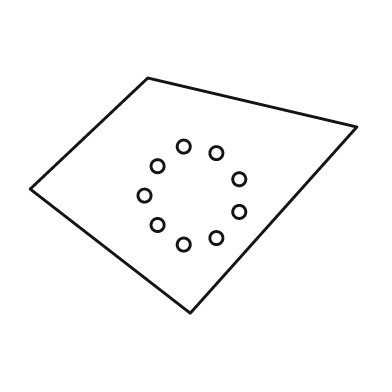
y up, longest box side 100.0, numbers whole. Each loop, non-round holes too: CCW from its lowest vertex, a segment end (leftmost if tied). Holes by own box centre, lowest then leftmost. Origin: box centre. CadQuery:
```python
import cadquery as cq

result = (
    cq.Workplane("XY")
    .moveTo(-1.0, -36.0)
    .lineTo(50.0, 21.0)
    .lineTo(-14.0, 36.0)
    .lineTo(-50.0, 2.0)
    .close()
    .moveTo(-3.0, -15.0)
    .circle(2.0)
    .moveTo(7.0, -13.0)
    .circle(2.0)
    .moveTo(-11.0, -9.0)
    .circle(2.0)
    .moveTo(14.0, -5.0)
    .circle(2.0)
    .moveTo(-15.0, 0.0)
    .circle(2.0)
    .moveTo(14.0, 5.0)
    .circle(2.0)
    .moveTo(-11.0, 9.0)
    .circle(2.0)
    .moveTo(7.0, 13.0)
    .circle(2.0)
    .moveTo(-3.0, 15.0)
    .circle(2.0)
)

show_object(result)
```